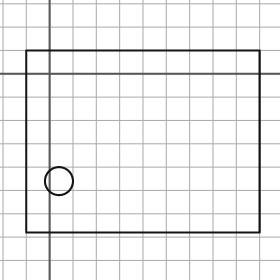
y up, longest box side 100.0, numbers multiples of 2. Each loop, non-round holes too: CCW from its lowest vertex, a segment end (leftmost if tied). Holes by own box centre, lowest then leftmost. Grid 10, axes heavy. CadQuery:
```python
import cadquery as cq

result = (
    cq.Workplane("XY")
    .moveTo(-10.0, -68.0)
    .lineTo(90.0, -68.0)
    .lineTo(90.0, 10.0)
    .lineTo(-10.0, 10.0)
    .close()
    .moveTo(4.0, -46.0)
    .circle(6.0)
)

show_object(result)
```